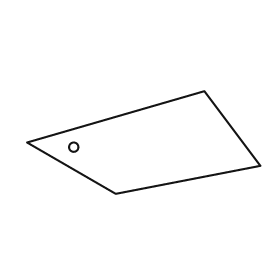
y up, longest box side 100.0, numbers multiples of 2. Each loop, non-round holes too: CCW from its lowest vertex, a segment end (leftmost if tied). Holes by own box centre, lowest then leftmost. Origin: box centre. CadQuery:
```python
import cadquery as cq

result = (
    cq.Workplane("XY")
    .moveTo(-12.0, -22.0)
    .lineTo(50.0, -10.0)
    .lineTo(26.0, 22.0)
    .lineTo(-50.0, 0.0)
    .close()
    .moveTo(-30.0, -2.0)
    .circle(2.0)
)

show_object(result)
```